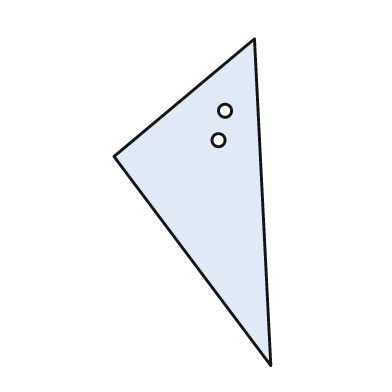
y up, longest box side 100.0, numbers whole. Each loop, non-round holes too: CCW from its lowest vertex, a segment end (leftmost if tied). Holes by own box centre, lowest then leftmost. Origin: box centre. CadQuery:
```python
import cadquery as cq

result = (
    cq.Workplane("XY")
    .moveTo(24.0, -50.0)
    .lineTo(19.0, 50.0)
    .lineTo(-24.0, 14.0)
    .close()
    .moveTo(8.0, 19.0)
    .circle(2.0)
    .moveTo(10.0, 28.0)
    .circle(2.0)
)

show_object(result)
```